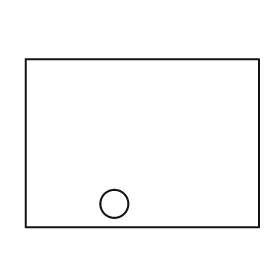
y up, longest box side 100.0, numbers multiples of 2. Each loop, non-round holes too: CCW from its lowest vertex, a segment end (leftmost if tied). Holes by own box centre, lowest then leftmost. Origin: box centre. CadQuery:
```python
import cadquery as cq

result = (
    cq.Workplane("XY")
    .moveTo(-50.0, -36.0)
    .lineTo(50.0, -36.0)
    .lineTo(50.0, 36.0)
    .lineTo(-50.0, 36.0)
    .close()
    .moveTo(-12.0, -26.0)
    .circle(6.0)
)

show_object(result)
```